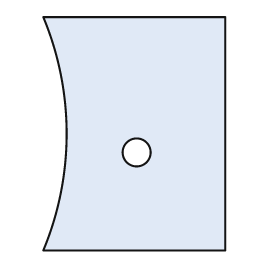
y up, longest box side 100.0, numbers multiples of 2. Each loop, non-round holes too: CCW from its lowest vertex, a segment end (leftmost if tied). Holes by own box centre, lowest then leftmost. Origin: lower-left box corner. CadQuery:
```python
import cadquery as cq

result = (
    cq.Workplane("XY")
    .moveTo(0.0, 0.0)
    .lineTo(78.0, 0.0)
    .lineTo(78.0, 100.0)
    .lineTo(0.0, 100.0)
    .threePointArc((10.0, 50.0), (0.0, 0.0))
    .close()
    .moveTo(40.0, 42.0)
    .circle(6.0)
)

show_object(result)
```